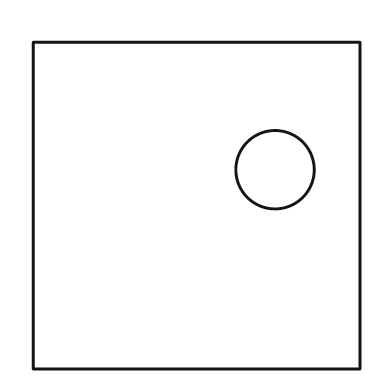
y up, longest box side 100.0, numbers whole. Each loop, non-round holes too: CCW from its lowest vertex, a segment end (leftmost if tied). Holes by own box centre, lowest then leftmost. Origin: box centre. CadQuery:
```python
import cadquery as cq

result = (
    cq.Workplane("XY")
    .moveTo(-50.0, -50.0)
    .lineTo(50.0, -50.0)
    .lineTo(50.0, 50.0)
    .lineTo(-50.0, 50.0)
    .close()
    .moveTo(24.0, 11.0)
    .circle(12.0)
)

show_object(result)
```